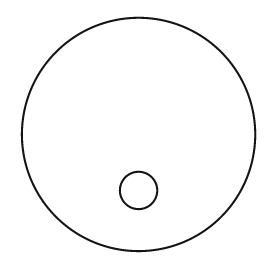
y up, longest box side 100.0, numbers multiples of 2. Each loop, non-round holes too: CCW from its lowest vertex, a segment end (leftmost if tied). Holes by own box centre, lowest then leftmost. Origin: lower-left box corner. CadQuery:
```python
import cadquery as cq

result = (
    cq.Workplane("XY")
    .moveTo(50.0, 50.0)
    .circle(50.0)
    .moveTo(50.0, 26.0)
    .circle(8.0)
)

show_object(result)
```